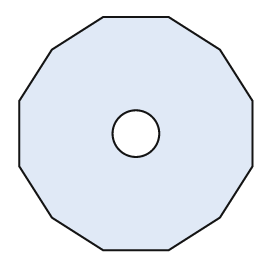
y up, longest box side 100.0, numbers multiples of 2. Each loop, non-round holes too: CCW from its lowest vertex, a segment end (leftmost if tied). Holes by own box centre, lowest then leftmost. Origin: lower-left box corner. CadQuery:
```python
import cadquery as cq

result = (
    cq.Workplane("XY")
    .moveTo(36.0, 0.0)
    .lineTo(64.0, 0.0)
    .lineTo(86.0, 14.0)
    .lineTo(100.0, 36.0)
    .lineTo(100.0, 64.0)
    .lineTo(86.0, 86.0)
    .lineTo(64.0, 100.0)
    .lineTo(36.0, 100.0)
    .lineTo(14.0, 86.0)
    .lineTo(0.0, 64.0)
    .lineTo(0.0, 36.0)
    .lineTo(14.0, 14.0)
    .close()
    .moveTo(50.0, 50.0)
    .circle(10.0)
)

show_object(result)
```